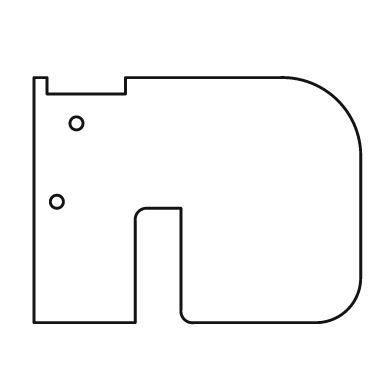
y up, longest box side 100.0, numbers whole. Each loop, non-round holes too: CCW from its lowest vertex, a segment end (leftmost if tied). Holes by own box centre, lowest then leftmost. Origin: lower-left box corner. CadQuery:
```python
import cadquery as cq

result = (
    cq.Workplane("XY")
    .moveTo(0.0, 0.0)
    .lineTo(31.0, 0.0)
    .lineTo(31.0, 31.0)
    .threePointArc((32.0, 34.0), (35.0, 35.0))
    .lineTo(45.0, 35.0)
    .lineTo(45.0, 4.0)
    .threePointArc((46.0, 1.0), (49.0, 0.0))
    .lineTo(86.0, 0.0)
    .threePointArc((96.0, 4.0), (100.0, 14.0))
    .lineTo(100.0, 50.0)
    .threePointArc((93.0, 68.0), (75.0, 75.0))
    .lineTo(28.0, 75.0)
    .lineTo(28.0, 70.0)
    .lineTo(4.0, 70.0)
    .lineTo(4.0, 75.0)
    .lineTo(0.0, 75.0)
    .close()
    .moveTo(7.0, 37.0)
    .circle(2.0)
    .moveTo(13.0, 61.0)
    .circle(2.0)
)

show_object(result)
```